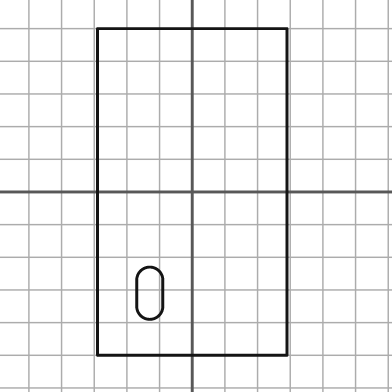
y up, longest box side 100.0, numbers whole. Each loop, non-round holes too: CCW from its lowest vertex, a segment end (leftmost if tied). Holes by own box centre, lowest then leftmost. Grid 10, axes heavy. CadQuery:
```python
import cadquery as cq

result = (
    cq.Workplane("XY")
    .moveTo(-29.0, -50.0)
    .lineTo(29.0, -50.0)
    .lineTo(29.0, 50.0)
    .lineTo(-29.0, 50.0)
    .close()
    .moveTo(-17.0, -35.0)
    .threePointArc((-13.0, -39.0), (-9.0, -35.0))
    .lineTo(-9.0, -27.0)
    .threePointArc((-13.0, -23.0), (-17.0, -27.0))
    .close()
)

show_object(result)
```